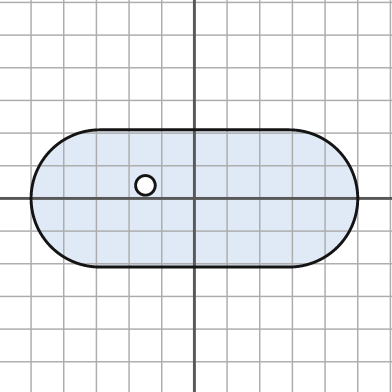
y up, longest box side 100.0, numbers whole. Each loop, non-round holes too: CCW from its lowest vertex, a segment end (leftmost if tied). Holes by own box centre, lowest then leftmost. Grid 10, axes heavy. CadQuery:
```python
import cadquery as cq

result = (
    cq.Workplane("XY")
    .moveTo(-29.0, -21.0)
    .lineTo(29.0, -21.0)
    .threePointArc((50.0, 0.0), (29.0, 21.0))
    .lineTo(-29.0, 21.0)
    .threePointArc((-50.0, 0.0), (-29.0, -21.0))
    .close()
    .moveTo(-15.0, 4.0)
    .circle(3.0)
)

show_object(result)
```